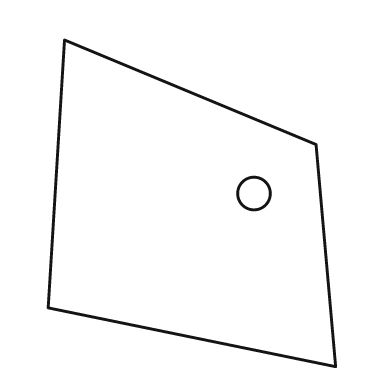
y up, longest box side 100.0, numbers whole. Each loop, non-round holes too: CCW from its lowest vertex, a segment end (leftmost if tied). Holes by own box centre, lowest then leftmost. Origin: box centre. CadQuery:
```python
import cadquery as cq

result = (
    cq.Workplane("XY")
    .moveTo(44.0, -50.0)
    .lineTo(38.0, 18.0)
    .lineTo(-39.0, 50.0)
    .lineTo(-44.0, -32.0)
    .close()
    .moveTo(19.0, 3.0)
    .circle(5.0)
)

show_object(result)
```